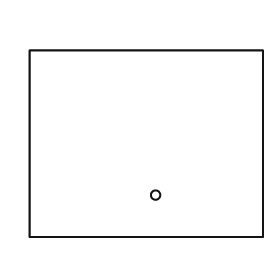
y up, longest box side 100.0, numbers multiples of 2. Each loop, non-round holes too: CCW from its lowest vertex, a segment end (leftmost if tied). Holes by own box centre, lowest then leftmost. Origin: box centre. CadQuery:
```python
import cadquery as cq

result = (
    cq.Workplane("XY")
    .moveTo(-50.0, -40.0)
    .lineTo(50.0, -40.0)
    .lineTo(50.0, 40.0)
    .lineTo(-50.0, 40.0)
    .close()
    .moveTo(4.0, -22.0)
    .circle(2.0)
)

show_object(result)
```